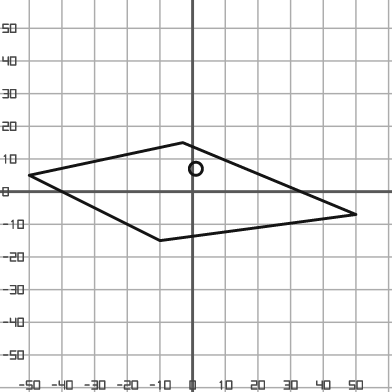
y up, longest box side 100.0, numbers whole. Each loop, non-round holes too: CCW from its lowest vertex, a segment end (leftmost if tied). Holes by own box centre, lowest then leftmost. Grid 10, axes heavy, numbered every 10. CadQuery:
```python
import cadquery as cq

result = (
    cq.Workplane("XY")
    .moveTo(-10.0, -15.0)
    .lineTo(50.0, -7.0)
    .lineTo(-3.0, 15.0)
    .lineTo(-50.0, 5.0)
    .close()
    .moveTo(1.0, 7.0)
    .circle(2.0)
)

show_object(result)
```